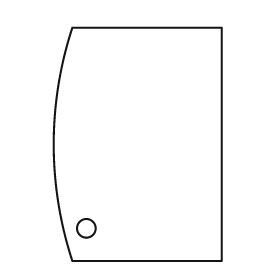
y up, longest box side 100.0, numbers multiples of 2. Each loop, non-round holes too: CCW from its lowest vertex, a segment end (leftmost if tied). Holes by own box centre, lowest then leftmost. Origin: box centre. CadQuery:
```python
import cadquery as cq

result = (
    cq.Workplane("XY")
    .moveTo(-28.0, -50.0)
    .lineTo(36.0, -50.0)
    .lineTo(36.0, 50.0)
    .lineTo(-28.0, 50.0)
    .threePointArc((-36.0, 0.0), (-28.0, -50.0))
    .close()
    .moveTo(-22.0, -36.0)
    .circle(4.0)
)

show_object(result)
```